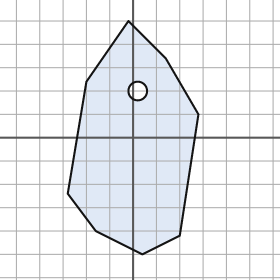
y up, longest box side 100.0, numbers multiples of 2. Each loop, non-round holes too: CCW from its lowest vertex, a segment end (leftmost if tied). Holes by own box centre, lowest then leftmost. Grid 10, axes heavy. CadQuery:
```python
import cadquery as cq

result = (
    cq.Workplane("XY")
    .moveTo(4.0, -50.0)
    .lineTo(20.0, -42.0)
    .lineTo(28.0, 10.0)
    .lineTo(14.0, 34.0)
    .lineTo(-2.0, 50.0)
    .lineTo(-20.0, 24.0)
    .lineTo(-28.0, -24.0)
    .lineTo(-16.0, -40.0)
    .close()
    .moveTo(2.0, 20.0)
    .circle(4.0)
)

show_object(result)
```